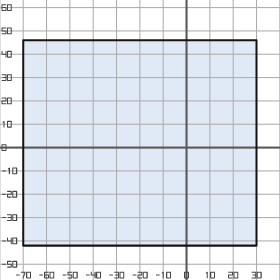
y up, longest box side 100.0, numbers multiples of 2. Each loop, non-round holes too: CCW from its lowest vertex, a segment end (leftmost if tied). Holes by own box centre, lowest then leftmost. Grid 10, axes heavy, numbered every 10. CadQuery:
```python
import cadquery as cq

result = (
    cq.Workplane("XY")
    .moveTo(-70.0, -42.0)
    .lineTo(30.0, -42.0)
    .lineTo(30.0, 46.0)
    .lineTo(-70.0, 46.0)
    .close()
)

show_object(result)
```